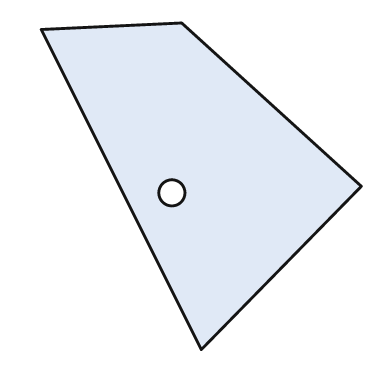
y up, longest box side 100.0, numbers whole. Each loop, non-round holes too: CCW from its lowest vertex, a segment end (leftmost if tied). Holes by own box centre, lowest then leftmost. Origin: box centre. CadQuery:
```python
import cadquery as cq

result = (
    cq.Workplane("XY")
    .moveTo(0.0, -50.0)
    .lineTo(49.0, 0.0)
    .lineTo(-6.0, 50.0)
    .lineTo(-49.0, 48.0)
    .close()
    .moveTo(-9.0, -2.0)
    .circle(4.0)
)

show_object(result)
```